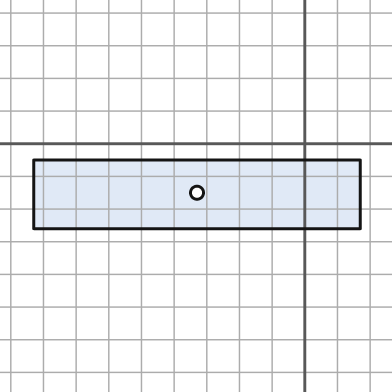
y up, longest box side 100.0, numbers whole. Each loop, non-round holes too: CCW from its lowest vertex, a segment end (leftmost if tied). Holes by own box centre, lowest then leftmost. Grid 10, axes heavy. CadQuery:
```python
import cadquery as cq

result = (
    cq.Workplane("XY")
    .moveTo(-83.0, -26.0)
    .lineTo(17.0, -26.0)
    .lineTo(17.0, -5.0)
    .lineTo(-83.0, -5.0)
    .close()
    .moveTo(-33.0, -15.0)
    .circle(2.0)
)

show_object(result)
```